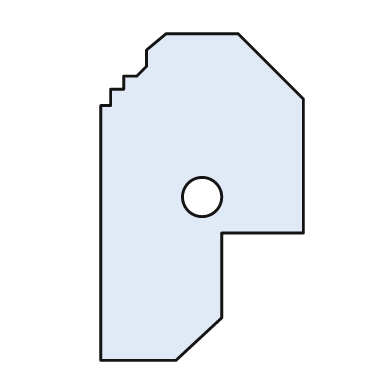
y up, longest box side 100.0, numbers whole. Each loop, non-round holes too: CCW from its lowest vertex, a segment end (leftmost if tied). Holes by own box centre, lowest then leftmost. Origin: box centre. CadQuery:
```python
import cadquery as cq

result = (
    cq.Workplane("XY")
    .moveTo(-31.0, -50.0)
    .lineTo(-8.0, -50.0)
    .lineTo(6.0, -37.0)
    .lineTo(6.0, -11.0)
    .lineTo(31.0, -11.0)
    .lineTo(31.0, 30.0)
    .lineTo(11.0, 50.0)
    .lineTo(-11.0, 50.0)
    .lineTo(-17.0, 45.0)
    .lineTo(-17.0, 40.0)
    .lineTo(-20.0, 37.0)
    .lineTo(-24.0, 37.0)
    .lineTo(-24.0, 33.0)
    .lineTo(-28.0, 33.0)
    .lineTo(-28.0, 28.0)
    .lineTo(-31.0, 28.0)
    .close()
    .moveTo(0.0, 0.0)
    .circle(6.0)
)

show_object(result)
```